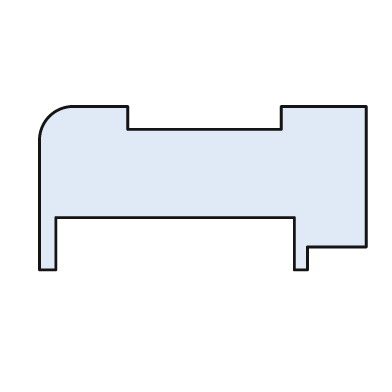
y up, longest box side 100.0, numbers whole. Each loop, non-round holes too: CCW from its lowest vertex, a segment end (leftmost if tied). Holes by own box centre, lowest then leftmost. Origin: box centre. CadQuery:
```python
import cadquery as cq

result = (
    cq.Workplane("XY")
    .moveTo(-50.0, -25.0)
    .lineTo(-45.0, -25.0)
    .lineTo(-45.0, -9.0)
    .lineTo(28.0, -9.0)
    .lineTo(28.0, -25.0)
    .lineTo(32.0, -25.0)
    .lineTo(32.0, -18.0)
    .lineTo(50.0, -18.0)
    .lineTo(50.0, 25.0)
    .lineTo(24.0, 25.0)
    .lineTo(24.0, 18.0)
    .lineTo(-23.0, 18.0)
    .lineTo(-23.0, 25.0)
    .lineTo(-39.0, 25.0)
    .threePointArc((-47.0, 22.0), (-50.0, 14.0))
    .close()
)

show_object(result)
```